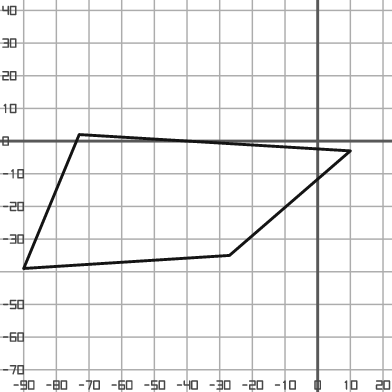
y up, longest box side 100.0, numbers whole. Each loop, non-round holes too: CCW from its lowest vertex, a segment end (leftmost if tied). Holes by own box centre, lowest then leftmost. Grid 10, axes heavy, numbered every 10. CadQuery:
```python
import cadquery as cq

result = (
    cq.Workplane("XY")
    .moveTo(-90.0, -39.0)
    .lineTo(-27.0, -35.0)
    .lineTo(10.0, -3.0)
    .lineTo(-73.0, 2.0)
    .close()
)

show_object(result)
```